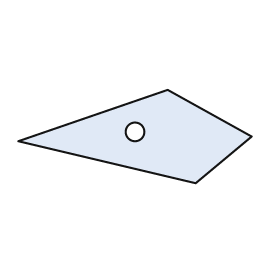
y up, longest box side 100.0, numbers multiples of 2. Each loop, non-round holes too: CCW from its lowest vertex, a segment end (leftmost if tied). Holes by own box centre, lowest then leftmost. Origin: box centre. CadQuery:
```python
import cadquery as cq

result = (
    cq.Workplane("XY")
    .moveTo(26.0, -20.0)
    .lineTo(50.0, 0.0)
    .lineTo(14.0, 20.0)
    .lineTo(-50.0, -2.0)
    .close()
    .moveTo(0.0, 2.0)
    .circle(4.0)
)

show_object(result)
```